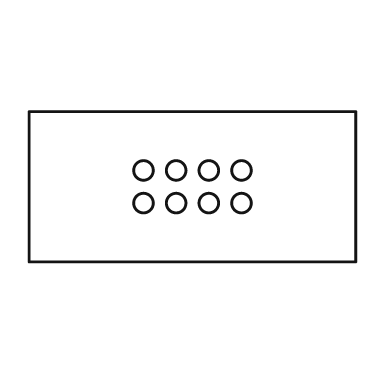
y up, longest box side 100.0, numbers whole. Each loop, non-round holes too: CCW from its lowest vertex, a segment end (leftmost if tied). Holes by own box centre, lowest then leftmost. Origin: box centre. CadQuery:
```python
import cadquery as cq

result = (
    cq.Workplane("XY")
    .moveTo(-50.0, -23.0)
    .lineTo(50.0, -23.0)
    .lineTo(50.0, 23.0)
    .lineTo(-50.0, 23.0)
    .close()
    .moveTo(-15.0, -5.0)
    .circle(3.0)
    .moveTo(-5.0, -5.0)
    .circle(3.0)
    .moveTo(5.0, -5.0)
    .circle(3.0)
    .moveTo(15.0, -5.0)
    .circle(3.0)
    .moveTo(-15.0, 5.0)
    .circle(3.0)
    .moveTo(-5.0, 5.0)
    .circle(3.0)
    .moveTo(5.0, 5.0)
    .circle(3.0)
    .moveTo(15.0, 5.0)
    .circle(3.0)
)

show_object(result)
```